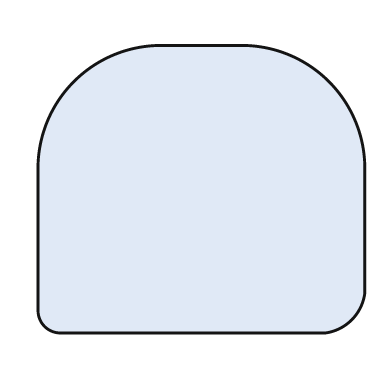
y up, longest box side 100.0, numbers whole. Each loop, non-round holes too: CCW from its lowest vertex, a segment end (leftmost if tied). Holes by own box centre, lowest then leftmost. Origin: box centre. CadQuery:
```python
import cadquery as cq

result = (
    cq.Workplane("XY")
    .moveTo(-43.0, -44.0)
    .lineTo(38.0, -44.0)
    .threePointArc((46.0, -40.0), (50.0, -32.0))
    .lineTo(50.0, 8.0)
    .threePointArc((39.0, 33.0), (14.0, 44.0))
    .lineTo(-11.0, 44.0)
    .threePointArc((-39.0, 33.0), (-50.0, 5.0))
    .lineTo(-50.0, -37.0)
    .threePointArc((-48.0, -42.0), (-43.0, -44.0))
    .close()
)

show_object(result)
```